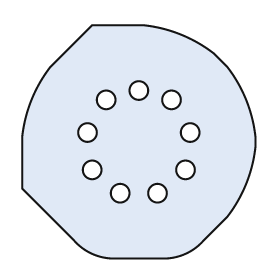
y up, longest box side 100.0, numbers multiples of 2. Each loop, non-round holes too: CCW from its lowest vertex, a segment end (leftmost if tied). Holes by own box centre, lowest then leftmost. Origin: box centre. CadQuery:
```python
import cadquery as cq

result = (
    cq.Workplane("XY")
    .moveTo(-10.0, -50.0)
    .lineTo(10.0, -50.0)
    .threePointArc((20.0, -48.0), (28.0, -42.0))
    .lineTo(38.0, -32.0)
    .threePointArc((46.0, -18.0), (50.0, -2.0))
    .lineTo(50.0, 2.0)
    .threePointArc((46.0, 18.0), (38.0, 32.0))
    .lineTo(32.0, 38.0)
    .threePointArc((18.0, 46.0), (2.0, 50.0))
    .lineTo(-20.0, 50.0)
    .lineTo(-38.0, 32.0)
    .threePointArc((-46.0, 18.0), (-50.0, 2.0))
    .lineTo(-50.0, -20.0)
    .lineTo(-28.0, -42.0)
    .threePointArc((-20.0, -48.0), (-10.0, -50.0))
    .close()
    .moveTo(-8.0, -22.0)
    .circle(4.0)
    .moveTo(8.0, -22.0)
    .circle(4.0)
    .moveTo(-20.0, -12.0)
    .circle(4.0)
    .moveTo(20.0, -12.0)
    .circle(4.0)
    .moveTo(-22.0, 4.0)
    .circle(4.0)
    .moveTo(22.0, 4.0)
    .circle(4.0)
    .moveTo(-14.0, 18.0)
    .circle(4.0)
    .moveTo(14.0, 18.0)
    .circle(4.0)
    .moveTo(0.0, 22.0)
    .circle(4.0)
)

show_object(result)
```